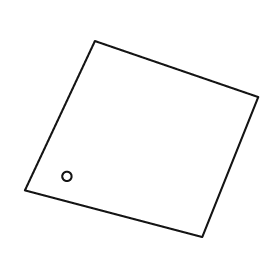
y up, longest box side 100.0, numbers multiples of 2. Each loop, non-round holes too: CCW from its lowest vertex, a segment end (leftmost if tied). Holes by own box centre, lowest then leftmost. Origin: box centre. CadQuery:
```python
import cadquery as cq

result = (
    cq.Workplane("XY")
    .moveTo(26.0, -42.0)
    .lineTo(50.0, 18.0)
    .lineTo(-20.0, 42.0)
    .lineTo(-50.0, -22.0)
    .close()
    .moveTo(-32.0, -16.0)
    .circle(2.0)
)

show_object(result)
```